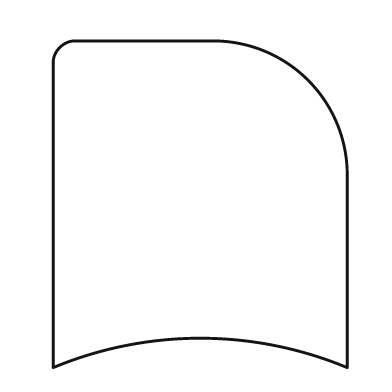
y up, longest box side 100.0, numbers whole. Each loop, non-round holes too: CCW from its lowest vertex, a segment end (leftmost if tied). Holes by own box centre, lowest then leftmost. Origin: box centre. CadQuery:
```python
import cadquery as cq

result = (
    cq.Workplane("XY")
    .moveTo(-45.0, -50.0)
    .threePointArc((0.0, -41.0), (45.0, -50.0))
    .lineTo(45.0, 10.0)
    .threePointArc((33.0, 38.0), (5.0, 50.0))
    .lineTo(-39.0, 50.0)
    .threePointArc((-43.0, 48.0), (-45.0, 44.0))
    .close()
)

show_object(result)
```